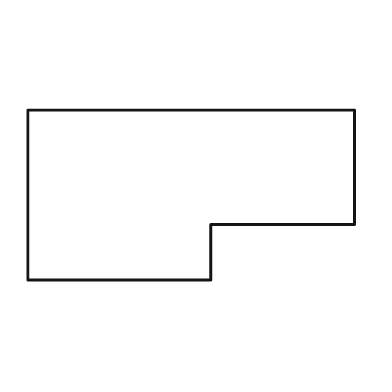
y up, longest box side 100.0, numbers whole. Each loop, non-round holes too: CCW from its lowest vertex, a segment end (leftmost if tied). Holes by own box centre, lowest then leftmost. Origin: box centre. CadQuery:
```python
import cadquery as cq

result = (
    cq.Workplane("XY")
    .moveTo(-50.0, -26.0)
    .lineTo(6.0, -26.0)
    .lineTo(6.0, -9.0)
    .lineTo(50.0, -9.0)
    .lineTo(50.0, 26.0)
    .lineTo(-50.0, 26.0)
    .close()
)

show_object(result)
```